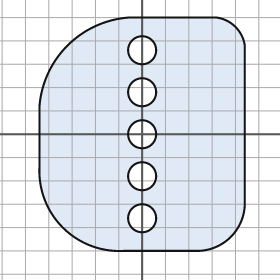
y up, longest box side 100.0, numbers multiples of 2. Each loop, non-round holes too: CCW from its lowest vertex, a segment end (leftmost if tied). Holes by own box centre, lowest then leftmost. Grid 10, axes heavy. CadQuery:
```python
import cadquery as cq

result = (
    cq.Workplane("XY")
    .moveTo(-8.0, -50.0)
    .lineTo(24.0, -50.0)
    .threePointArc((38.0, -44.0), (44.0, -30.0))
    .lineTo(44.0, 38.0)
    .threePointArc((40.0, 46.0), (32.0, 50.0))
    .lineTo(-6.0, 50.0)
    .threePointArc((-32.0, 38.0), (-44.0, 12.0))
    .lineTo(-44.0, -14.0)
    .threePointArc((-34.0, -40.0), (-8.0, -50.0))
    .close()
    .moveTo(0.0, -36.0)
    .circle(6.0)
    .moveTo(0.0, -18.0)
    .circle(6.0)
    .moveTo(0.0, 0.0)
    .circle(6.0)
    .moveTo(0.0, 18.0)
    .circle(6.0)
    .moveTo(0.0, 36.0)
    .circle(6.0)
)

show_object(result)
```